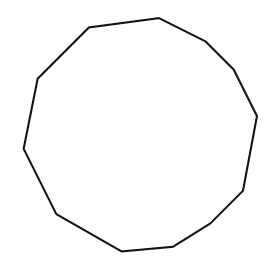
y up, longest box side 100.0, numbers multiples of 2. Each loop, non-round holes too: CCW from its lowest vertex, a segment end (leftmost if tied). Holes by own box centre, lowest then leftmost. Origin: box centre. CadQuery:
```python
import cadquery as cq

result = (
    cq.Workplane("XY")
    .moveTo(-8.0, -50.0)
    .lineTo(14.0, -48.0)
    .lineTo(30.0, -38.0)
    .lineTo(44.0, -24.0)
    .lineTo(50.0, 8.0)
    .lineTo(40.0, 28.0)
    .lineTo(28.0, 40.0)
    .lineTo(8.0, 50.0)
    .lineTo(-22.0, 46.0)
    .lineTo(-44.0, 24.0)
    .lineTo(-50.0, -6.0)
    .lineTo(-36.0, -34.0)
    .close()
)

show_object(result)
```